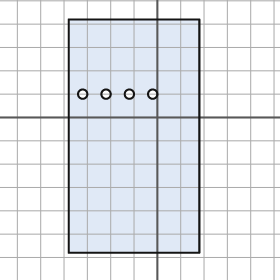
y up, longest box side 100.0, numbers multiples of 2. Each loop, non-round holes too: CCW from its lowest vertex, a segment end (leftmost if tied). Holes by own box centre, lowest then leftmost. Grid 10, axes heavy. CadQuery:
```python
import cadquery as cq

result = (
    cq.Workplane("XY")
    .moveTo(-38.0, -58.0)
    .lineTo(18.0, -58.0)
    .lineTo(18.0, 42.0)
    .lineTo(-38.0, 42.0)
    .close()
    .moveTo(-32.0, 10.0)
    .circle(2.0)
    .moveTo(-22.0, 10.0)
    .circle(2.0)
    .moveTo(-12.0, 10.0)
    .circle(2.0)
    .moveTo(-2.0, 10.0)
    .circle(2.0)
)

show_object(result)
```